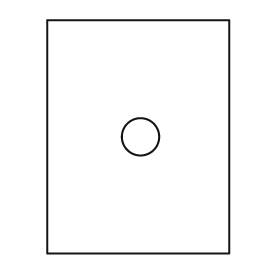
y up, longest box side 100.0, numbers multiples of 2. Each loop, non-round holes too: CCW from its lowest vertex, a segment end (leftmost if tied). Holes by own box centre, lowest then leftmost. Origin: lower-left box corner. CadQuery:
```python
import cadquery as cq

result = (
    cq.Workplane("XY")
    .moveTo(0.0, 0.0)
    .lineTo(78.0, 0.0)
    .lineTo(78.0, 100.0)
    .lineTo(0.0, 100.0)
    .close()
    .moveTo(40.0, 50.0)
    .circle(8.0)
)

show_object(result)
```